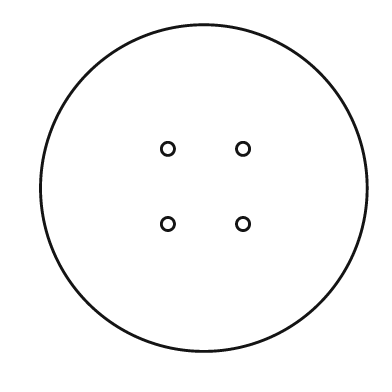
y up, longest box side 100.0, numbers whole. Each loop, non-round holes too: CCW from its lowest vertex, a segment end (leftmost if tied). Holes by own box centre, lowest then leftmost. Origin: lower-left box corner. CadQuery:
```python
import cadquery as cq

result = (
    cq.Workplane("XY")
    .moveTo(50.0, 50.0)
    .circle(50.0)
    .moveTo(39.0, 39.0)
    .circle(2.0)
    .moveTo(62.0, 39.0)
    .circle(2.0)
    .moveTo(39.0, 62.0)
    .circle(2.0)
    .moveTo(62.0, 62.0)
    .circle(2.0)
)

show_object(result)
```